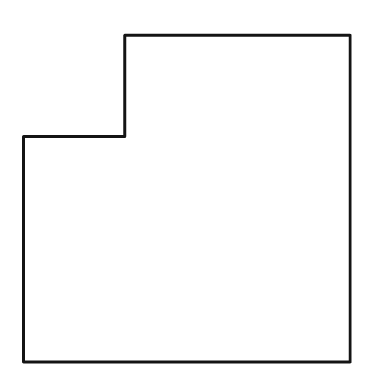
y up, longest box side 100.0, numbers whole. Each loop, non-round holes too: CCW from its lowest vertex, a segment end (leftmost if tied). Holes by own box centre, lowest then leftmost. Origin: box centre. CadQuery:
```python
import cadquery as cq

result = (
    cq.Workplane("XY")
    .moveTo(-50.0, -50.0)
    .lineTo(50.0, -50.0)
    .lineTo(50.0, 50.0)
    .lineTo(-19.0, 50.0)
    .lineTo(-19.0, 19.0)
    .lineTo(-50.0, 19.0)
    .close()
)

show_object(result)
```